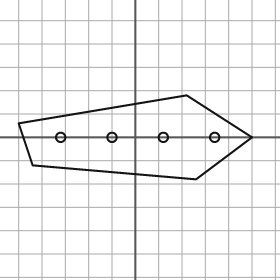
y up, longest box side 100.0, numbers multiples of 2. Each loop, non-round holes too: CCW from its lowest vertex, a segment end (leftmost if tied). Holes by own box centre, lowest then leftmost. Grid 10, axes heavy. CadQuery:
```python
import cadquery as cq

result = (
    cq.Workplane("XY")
    .moveTo(26.0, -18.0)
    .lineTo(50.0, 0.0)
    .lineTo(22.0, 18.0)
    .lineTo(-50.0, 6.0)
    .lineTo(-44.0, -12.0)
    .close()
    .moveTo(-32.0, 0.0)
    .circle(2.0)
    .moveTo(-10.0, 0.0)
    .circle(2.0)
    .moveTo(12.0, 0.0)
    .circle(2.0)
    .moveTo(34.0, 0.0)
    .circle(2.0)
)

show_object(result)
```